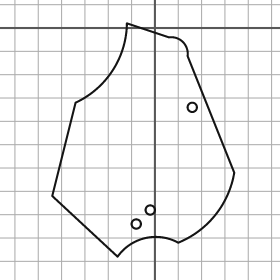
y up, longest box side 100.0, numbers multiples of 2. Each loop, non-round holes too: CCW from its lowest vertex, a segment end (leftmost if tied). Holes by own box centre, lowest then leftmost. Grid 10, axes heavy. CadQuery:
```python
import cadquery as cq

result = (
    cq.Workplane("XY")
    .moveTo(-16.0, -98.0)
    .threePointArc((-4.0, -90.0), (10.0, -92.0))
    .threePointArc((26.0, -80.0), (34.0, -62.0))
    .lineTo(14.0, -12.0)
    .threePointArc((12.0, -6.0), (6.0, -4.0))
    .lineTo(-12.0, 2.0)
    .threePointArc((-18.0, -18.0), (-34.0, -32.0))
    .lineTo(-44.0, -72.0)
    .close()
    .moveTo(-8.0, -84.0)
    .circle(2.0)
    .moveTo(-2.0, -78.0)
    .circle(2.0)
    .moveTo(16.0, -34.0)
    .circle(2.0)
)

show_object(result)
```